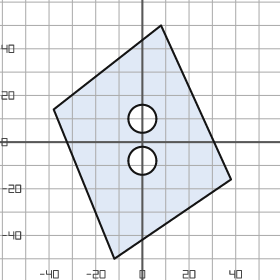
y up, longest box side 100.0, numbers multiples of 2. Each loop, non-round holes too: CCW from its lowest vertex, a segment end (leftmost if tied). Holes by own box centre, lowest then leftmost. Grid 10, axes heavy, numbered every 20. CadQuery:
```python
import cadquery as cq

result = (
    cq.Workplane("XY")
    .moveTo(-12.0, -50.0)
    .lineTo(38.0, -16.0)
    .lineTo(8.0, 50.0)
    .lineTo(-38.0, 14.0)
    .close()
    .moveTo(0.0, -8.0)
    .circle(6.0)
    .moveTo(0.0, 10.0)
    .circle(6.0)
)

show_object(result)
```